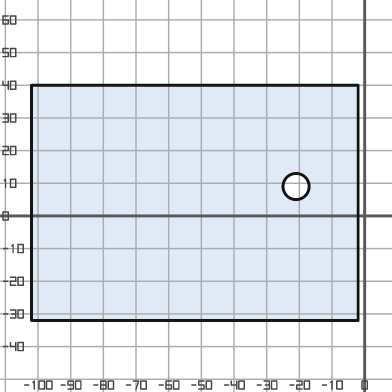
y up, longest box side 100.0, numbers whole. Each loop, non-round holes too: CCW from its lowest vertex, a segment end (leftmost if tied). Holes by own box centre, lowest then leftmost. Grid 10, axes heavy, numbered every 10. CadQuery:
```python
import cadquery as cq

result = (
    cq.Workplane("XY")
    .moveTo(-102.0, -32.0)
    .lineTo(-2.0, -32.0)
    .lineTo(-2.0, 40.0)
    .lineTo(-102.0, 40.0)
    .close()
    .moveTo(-21.0, 9.0)
    .circle(4.0)
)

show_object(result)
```